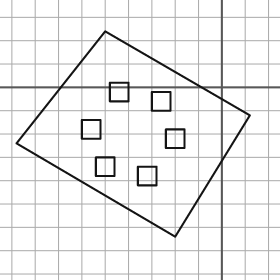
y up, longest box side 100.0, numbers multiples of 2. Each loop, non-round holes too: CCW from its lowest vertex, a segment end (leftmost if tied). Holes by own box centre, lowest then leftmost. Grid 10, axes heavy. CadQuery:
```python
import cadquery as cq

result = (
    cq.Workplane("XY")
    .moveTo(-20.0, -64.0)
    .lineTo(12.0, -12.0)
    .lineTo(-50.0, 24.0)
    .lineTo(-88.0, -24.0)
    .close()
    .moveTo(-36.0, -42.0)
    .lineTo(-28.0, -42.0)
    .lineTo(-28.0, -34.0)
    .lineTo(-36.0, -34.0)
    .close()
    .moveTo(-54.0, -38.0)
    .lineTo(-46.0, -38.0)
    .lineTo(-46.0, -30.0)
    .lineTo(-54.0, -30.0)
    .close()
    .moveTo(-24.0, -26.0)
    .lineTo(-16.0, -26.0)
    .lineTo(-16.0, -18.0)
    .lineTo(-24.0, -18.0)
    .close()
    .moveTo(-60.0, -22.0)
    .lineTo(-52.0, -22.0)
    .lineTo(-52.0, -14.0)
    .lineTo(-60.0, -14.0)
    .close()
    .moveTo(-30.0, -10.0)
    .lineTo(-22.0, -10.0)
    .lineTo(-22.0, -2.0)
    .lineTo(-30.0, -2.0)
    .close()
    .moveTo(-48.0, -6.0)
    .lineTo(-40.0, -6.0)
    .lineTo(-40.0, 2.0)
    .lineTo(-48.0, 2.0)
    .close()
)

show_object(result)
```